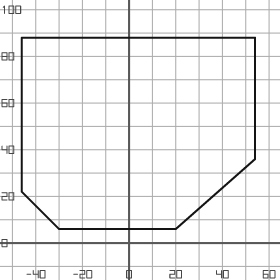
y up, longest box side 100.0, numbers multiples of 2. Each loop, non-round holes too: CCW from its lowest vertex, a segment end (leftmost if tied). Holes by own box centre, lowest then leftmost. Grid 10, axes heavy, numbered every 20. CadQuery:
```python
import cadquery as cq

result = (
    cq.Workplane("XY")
    .moveTo(-30.0, 6.0)
    .lineTo(20.0, 6.0)
    .lineTo(54.0, 36.0)
    .lineTo(54.0, 88.0)
    .lineTo(-46.0, 88.0)
    .lineTo(-46.0, 22.0)
    .close()
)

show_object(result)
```